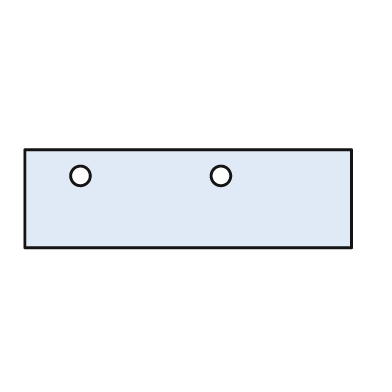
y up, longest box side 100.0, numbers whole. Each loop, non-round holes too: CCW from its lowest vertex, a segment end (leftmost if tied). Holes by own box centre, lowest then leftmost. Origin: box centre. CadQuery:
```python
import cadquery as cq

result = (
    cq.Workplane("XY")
    .moveTo(-50.0, -15.0)
    .lineTo(50.0, -15.0)
    .lineTo(50.0, 15.0)
    .lineTo(-50.0, 15.0)
    .close()
    .moveTo(-33.0, 7.0)
    .circle(3.0)
    .moveTo(10.0, 7.0)
    .circle(3.0)
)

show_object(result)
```